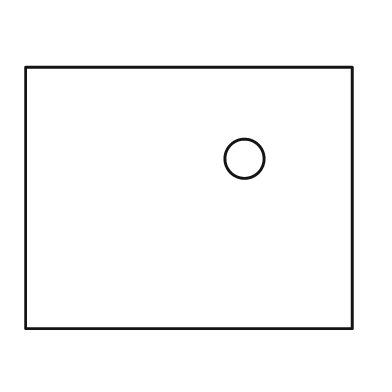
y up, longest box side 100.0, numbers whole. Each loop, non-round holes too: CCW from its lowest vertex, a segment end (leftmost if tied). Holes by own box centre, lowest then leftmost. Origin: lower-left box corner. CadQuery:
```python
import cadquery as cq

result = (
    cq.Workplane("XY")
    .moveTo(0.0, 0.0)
    .lineTo(100.0, 0.0)
    .lineTo(100.0, 80.0)
    .lineTo(0.0, 80.0)
    .close()
    .moveTo(67.0, 52.0)
    .circle(6.0)
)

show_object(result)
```